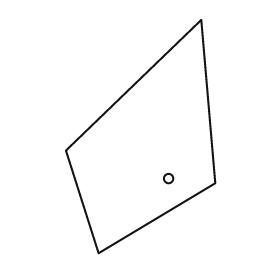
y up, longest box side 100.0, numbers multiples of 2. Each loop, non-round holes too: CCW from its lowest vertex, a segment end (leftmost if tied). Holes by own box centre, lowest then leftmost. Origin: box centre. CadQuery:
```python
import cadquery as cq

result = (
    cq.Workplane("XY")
    .moveTo(-18.0, -50.0)
    .lineTo(32.0, -20.0)
    .lineTo(26.0, 50.0)
    .lineTo(-32.0, -6.0)
    .close()
    .moveTo(12.0, -18.0)
    .circle(2.0)
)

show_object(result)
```